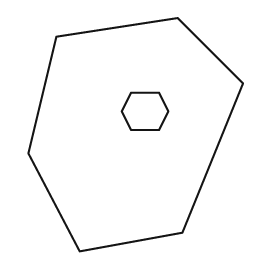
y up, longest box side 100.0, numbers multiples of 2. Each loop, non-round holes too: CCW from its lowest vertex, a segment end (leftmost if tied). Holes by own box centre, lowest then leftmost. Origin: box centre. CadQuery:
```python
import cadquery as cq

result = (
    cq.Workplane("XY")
    .moveTo(-24.0, -50.0)
    .lineTo(20.0, -42.0)
    .lineTo(46.0, 22.0)
    .lineTo(18.0, 50.0)
    .lineTo(-34.0, 42.0)
    .lineTo(-46.0, -8.0)
    .close()
    .moveTo(-2.0, 2.0)
    .lineTo(10.0, 2.0)
    .lineTo(14.0, 10.0)
    .lineTo(10.0, 18.0)
    .lineTo(-2.0, 18.0)
    .lineTo(-6.0, 10.0)
    .close()
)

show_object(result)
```